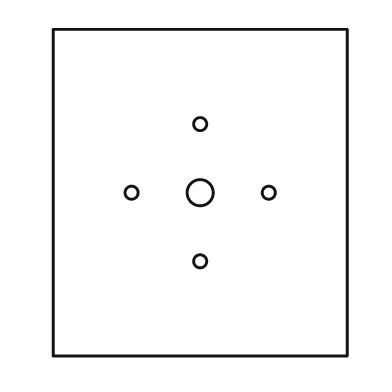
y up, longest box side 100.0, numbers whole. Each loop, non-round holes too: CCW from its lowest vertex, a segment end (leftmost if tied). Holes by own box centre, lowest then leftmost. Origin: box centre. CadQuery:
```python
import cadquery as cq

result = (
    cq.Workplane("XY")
    .moveTo(-45.0, -50.0)
    .lineTo(45.0, -50.0)
    .lineTo(45.0, 50.0)
    .lineTo(-45.0, 50.0)
    .close()
    .moveTo(0.0, -21.0)
    .circle(2.0)
    .moveTo(-21.0, 0.0)
    .circle(2.0)
    .moveTo(0.0, 0.0)
    .circle(4.0)
    .moveTo(21.0, 0.0)
    .circle(2.0)
    .moveTo(0.0, 21.0)
    .circle(2.0)
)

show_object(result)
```